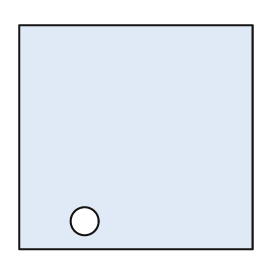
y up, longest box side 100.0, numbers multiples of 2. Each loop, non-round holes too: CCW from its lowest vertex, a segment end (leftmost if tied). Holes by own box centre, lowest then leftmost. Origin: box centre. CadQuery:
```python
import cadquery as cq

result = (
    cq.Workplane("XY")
    .moveTo(-50.0, -48.0)
    .lineTo(50.0, -48.0)
    .lineTo(50.0, 48.0)
    .lineTo(-50.0, 48.0)
    .close()
    .moveTo(-22.0, -36.0)
    .circle(6.0)
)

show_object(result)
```